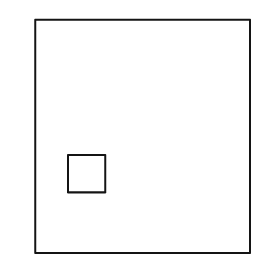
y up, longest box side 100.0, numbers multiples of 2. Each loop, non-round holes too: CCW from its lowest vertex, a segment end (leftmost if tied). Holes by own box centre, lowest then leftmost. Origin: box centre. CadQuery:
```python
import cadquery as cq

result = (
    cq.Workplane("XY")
    .moveTo(-46.0, -50.0)
    .lineTo(46.0, -50.0)
    .lineTo(46.0, 50.0)
    .lineTo(-46.0, 50.0)
    .close()
    .moveTo(-32.0, -24.0)
    .lineTo(-16.0, -24.0)
    .lineTo(-16.0, -8.0)
    .lineTo(-32.0, -8.0)
    .close()
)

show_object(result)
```